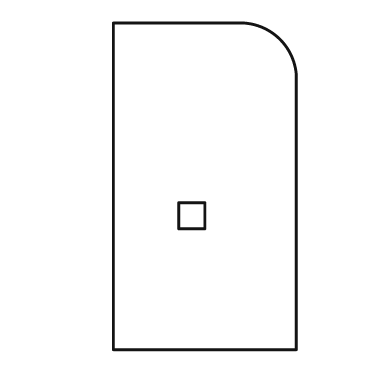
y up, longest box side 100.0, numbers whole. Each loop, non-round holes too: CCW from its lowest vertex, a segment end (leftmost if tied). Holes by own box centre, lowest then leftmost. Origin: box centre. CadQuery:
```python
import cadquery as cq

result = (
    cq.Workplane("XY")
    .moveTo(-28.0, -50.0)
    .lineTo(28.0, -50.0)
    .lineTo(28.0, 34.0)
    .threePointArc((23.0, 45.0), (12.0, 50.0))
    .lineTo(-28.0, 50.0)
    .close()
    .moveTo(-8.0, -13.0)
    .lineTo(0.0, -13.0)
    .lineTo(0.0, -5.0)
    .lineTo(-8.0, -5.0)
    .close()
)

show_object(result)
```